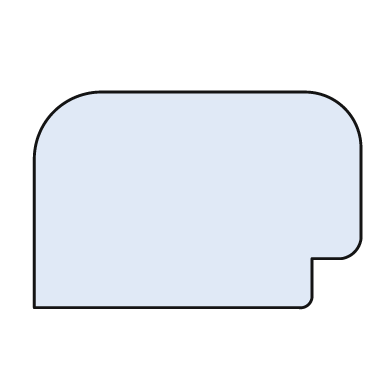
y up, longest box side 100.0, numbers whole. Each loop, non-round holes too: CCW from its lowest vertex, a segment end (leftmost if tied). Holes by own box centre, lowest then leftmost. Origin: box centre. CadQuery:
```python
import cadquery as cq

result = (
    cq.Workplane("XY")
    .moveTo(-50.0, -33.0)
    .lineTo(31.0, -33.0)
    .threePointArc((34.0, -32.0), (35.0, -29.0))
    .lineTo(35.0, -18.0)
    .lineTo(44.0, -18.0)
    .threePointArc((48.0, -16.0), (50.0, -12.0))
    .lineTo(50.0, 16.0)
    .threePointArc((45.0, 28.0), (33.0, 33.0))
    .lineTo(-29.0, 33.0)
    .threePointArc((-44.0, 27.0), (-50.0, 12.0))
    .close()
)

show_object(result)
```